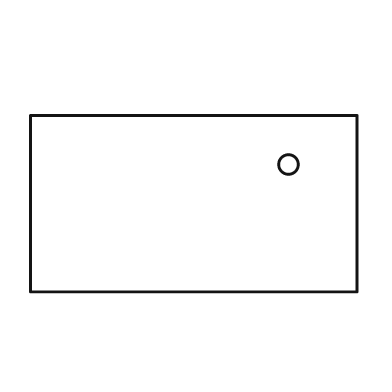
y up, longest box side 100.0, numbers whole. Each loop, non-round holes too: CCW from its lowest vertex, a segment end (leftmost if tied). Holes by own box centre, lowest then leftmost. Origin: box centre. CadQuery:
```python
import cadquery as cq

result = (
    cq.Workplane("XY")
    .moveTo(-50.0, -27.0)
    .lineTo(50.0, -27.0)
    .lineTo(50.0, 27.0)
    .lineTo(-50.0, 27.0)
    .close()
    .moveTo(29.0, 12.0)
    .circle(3.0)
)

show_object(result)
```